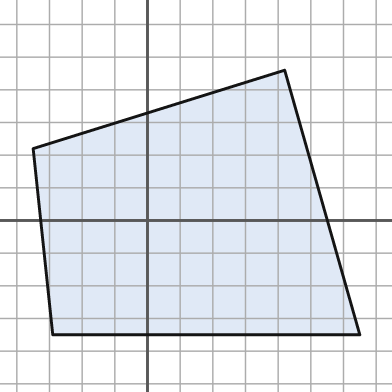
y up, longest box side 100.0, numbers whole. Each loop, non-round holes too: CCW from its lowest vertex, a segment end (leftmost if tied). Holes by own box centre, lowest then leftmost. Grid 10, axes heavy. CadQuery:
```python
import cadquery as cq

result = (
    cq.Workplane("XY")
    .moveTo(-29.0, -35.0)
    .lineTo(65.0, -35.0)
    .lineTo(42.0, 46.0)
    .lineTo(-35.0, 22.0)
    .close()
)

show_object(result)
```